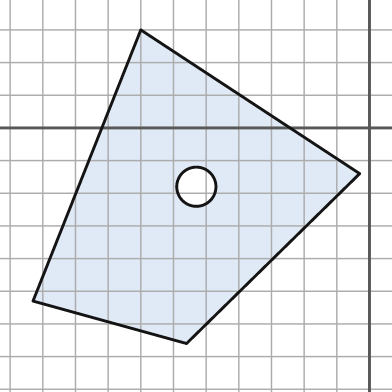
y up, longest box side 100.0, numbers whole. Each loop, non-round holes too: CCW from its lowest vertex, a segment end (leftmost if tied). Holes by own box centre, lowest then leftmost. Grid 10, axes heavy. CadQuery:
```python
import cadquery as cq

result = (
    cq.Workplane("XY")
    .moveTo(-56.0, -66.0)
    .lineTo(-3.0, -14.0)
    .lineTo(-70.0, 30.0)
    .lineTo(-103.0, -53.0)
    .close()
    .moveTo(-53.0, -18.0)
    .circle(6.0)
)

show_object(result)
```